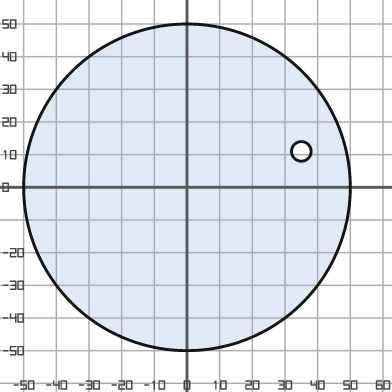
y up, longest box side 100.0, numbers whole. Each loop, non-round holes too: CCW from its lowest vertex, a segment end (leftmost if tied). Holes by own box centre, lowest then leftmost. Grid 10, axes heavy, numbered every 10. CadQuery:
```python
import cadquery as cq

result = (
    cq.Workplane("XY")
    .moveTo(0.0, 0.0)
    .circle(50.0)
    .moveTo(35.0, 11.0)
    .circle(3.0)
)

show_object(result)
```